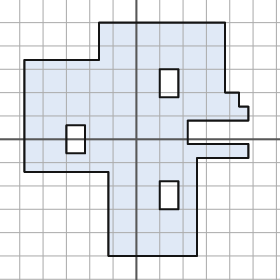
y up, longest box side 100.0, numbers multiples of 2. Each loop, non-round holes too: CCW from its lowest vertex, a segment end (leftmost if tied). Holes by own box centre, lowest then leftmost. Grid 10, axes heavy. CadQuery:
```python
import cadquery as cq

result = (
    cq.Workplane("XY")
    .moveTo(-12.0, -50.0)
    .lineTo(26.0, -50.0)
    .lineTo(26.0, -8.0)
    .lineTo(48.0, -8.0)
    .lineTo(48.0, -2.0)
    .lineTo(22.0, -2.0)
    .lineTo(22.0, 8.0)
    .lineTo(48.0, 8.0)
    .lineTo(48.0, 14.0)
    .lineTo(44.0, 14.0)
    .lineTo(44.0, 20.0)
    .lineTo(38.0, 20.0)
    .lineTo(38.0, 50.0)
    .lineTo(-16.0, 50.0)
    .lineTo(-16.0, 34.0)
    .lineTo(-48.0, 34.0)
    .lineTo(-48.0, -14.0)
    .lineTo(-12.0, -14.0)
    .close()
    .moveTo(10.0, -30.0)
    .lineTo(18.0, -30.0)
    .lineTo(18.0, -18.0)
    .lineTo(10.0, -18.0)
    .close()
    .moveTo(-30.0, -6.0)
    .lineTo(-22.0, -6.0)
    .lineTo(-22.0, 6.0)
    .lineTo(-30.0, 6.0)
    .close()
    .moveTo(10.0, 18.0)
    .lineTo(18.0, 18.0)
    .lineTo(18.0, 30.0)
    .lineTo(10.0, 30.0)
    .close()
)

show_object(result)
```